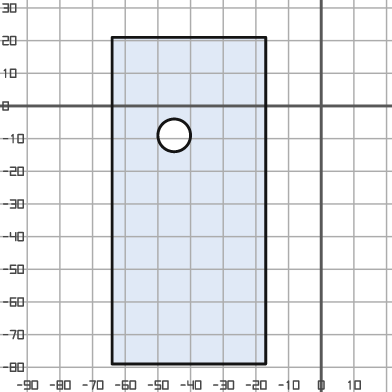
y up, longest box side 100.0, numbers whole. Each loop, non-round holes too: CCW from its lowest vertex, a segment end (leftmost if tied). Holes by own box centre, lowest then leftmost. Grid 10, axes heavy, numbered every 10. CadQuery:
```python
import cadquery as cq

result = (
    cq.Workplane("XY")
    .moveTo(-64.0, -79.0)
    .lineTo(-17.0, -79.0)
    .lineTo(-17.0, 21.0)
    .lineTo(-64.0, 21.0)
    .close()
    .moveTo(-45.0, -9.0)
    .circle(5.0)
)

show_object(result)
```